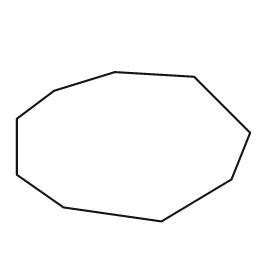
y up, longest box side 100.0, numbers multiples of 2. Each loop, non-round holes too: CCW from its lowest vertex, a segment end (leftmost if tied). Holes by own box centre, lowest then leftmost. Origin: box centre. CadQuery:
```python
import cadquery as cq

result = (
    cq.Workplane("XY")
    .moveTo(12.0, -32.0)
    .lineTo(42.0, -14.0)
    .lineTo(50.0, 6.0)
    .lineTo(26.0, 30.0)
    .lineTo(-8.0, 32.0)
    .lineTo(-34.0, 24.0)
    .lineTo(-50.0, 12.0)
    .lineTo(-50.0, -12.0)
    .lineTo(-30.0, -26.0)
    .close()
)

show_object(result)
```